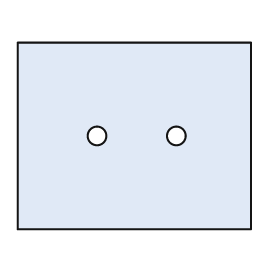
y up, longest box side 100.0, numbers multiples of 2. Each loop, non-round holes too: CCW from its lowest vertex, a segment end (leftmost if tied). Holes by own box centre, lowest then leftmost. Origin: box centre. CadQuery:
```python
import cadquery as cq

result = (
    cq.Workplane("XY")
    .moveTo(-50.0, -40.0)
    .lineTo(50.0, -40.0)
    .lineTo(50.0, 40.0)
    .lineTo(-50.0, 40.0)
    .close()
    .moveTo(-16.0, 0.0)
    .circle(4.0)
    .moveTo(18.0, 0.0)
    .circle(4.0)
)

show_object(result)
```